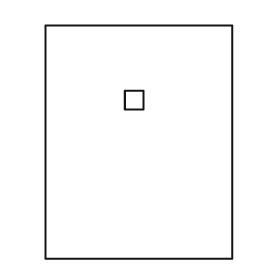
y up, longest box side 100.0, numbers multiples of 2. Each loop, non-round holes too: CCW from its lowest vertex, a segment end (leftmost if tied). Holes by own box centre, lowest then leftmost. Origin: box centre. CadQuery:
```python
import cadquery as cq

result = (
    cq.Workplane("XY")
    .moveTo(-40.0, -50.0)
    .lineTo(40.0, -50.0)
    .lineTo(40.0, 50.0)
    .lineTo(-40.0, 50.0)
    .close()
    .moveTo(-6.0, 14.0)
    .lineTo(2.0, 14.0)
    .lineTo(2.0, 22.0)
    .lineTo(-6.0, 22.0)
    .close()
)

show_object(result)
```